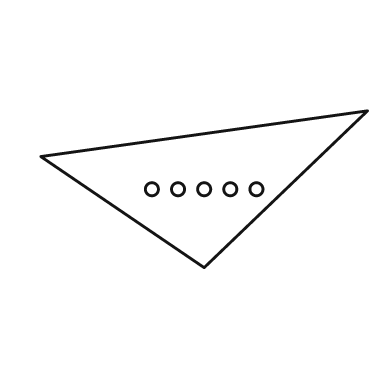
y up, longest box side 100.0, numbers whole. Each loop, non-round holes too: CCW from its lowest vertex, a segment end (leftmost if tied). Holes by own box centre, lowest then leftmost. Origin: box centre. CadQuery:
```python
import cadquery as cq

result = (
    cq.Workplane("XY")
    .moveTo(0.0, -24.0)
    .lineTo(50.0, 24.0)
    .lineTo(-50.0, 10.0)
    .close()
    .moveTo(-16.0, 0.0)
    .circle(2.0)
    .moveTo(-8.0, 0.0)
    .circle(2.0)
    .moveTo(0.0, 0.0)
    .circle(2.0)
    .moveTo(8.0, 0.0)
    .circle(2.0)
    .moveTo(16.0, 0.0)
    .circle(2.0)
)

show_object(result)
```